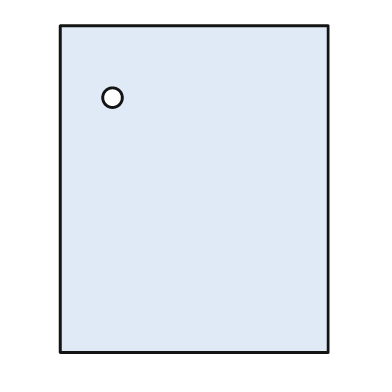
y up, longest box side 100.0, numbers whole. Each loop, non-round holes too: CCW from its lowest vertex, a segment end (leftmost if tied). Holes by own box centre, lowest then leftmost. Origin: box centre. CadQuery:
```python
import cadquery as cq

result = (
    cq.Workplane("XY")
    .moveTo(-41.0, -50.0)
    .lineTo(41.0, -50.0)
    .lineTo(41.0, 50.0)
    .lineTo(-41.0, 50.0)
    .close()
    .moveTo(-25.0, 28.0)
    .circle(3.0)
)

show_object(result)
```